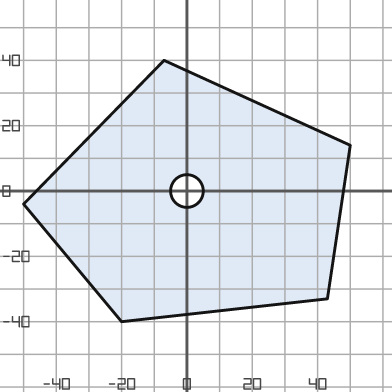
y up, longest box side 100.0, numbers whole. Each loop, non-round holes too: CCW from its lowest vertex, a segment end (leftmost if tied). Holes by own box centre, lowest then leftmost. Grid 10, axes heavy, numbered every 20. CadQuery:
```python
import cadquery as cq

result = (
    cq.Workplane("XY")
    .moveTo(-20.0, -40.0)
    .lineTo(43.0, -33.0)
    .lineTo(50.0, 14.0)
    .lineTo(-7.0, 40.0)
    .lineTo(-50.0, -4.0)
    .close()
    .moveTo(0.0, 0.0)
    .circle(5.0)
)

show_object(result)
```